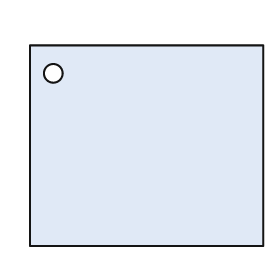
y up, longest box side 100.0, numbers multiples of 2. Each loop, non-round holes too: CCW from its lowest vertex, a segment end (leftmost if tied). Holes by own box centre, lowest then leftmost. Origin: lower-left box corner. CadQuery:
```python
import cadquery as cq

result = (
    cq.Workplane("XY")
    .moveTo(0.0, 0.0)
    .lineTo(100.0, 0.0)
    .lineTo(100.0, 86.0)
    .lineTo(0.0, 86.0)
    .close()
    .moveTo(10.0, 74.0)
    .circle(4.0)
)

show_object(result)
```